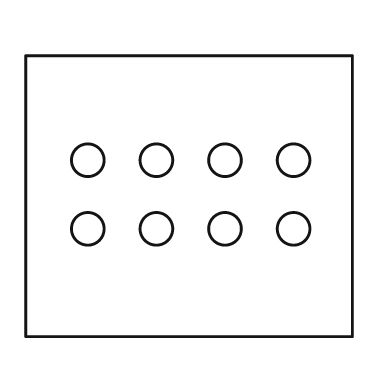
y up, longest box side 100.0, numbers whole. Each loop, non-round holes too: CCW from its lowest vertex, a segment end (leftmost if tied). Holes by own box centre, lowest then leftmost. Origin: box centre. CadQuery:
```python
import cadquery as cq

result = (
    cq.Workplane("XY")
    .moveTo(-50.0, -43.0)
    .lineTo(50.0, -43.0)
    .lineTo(50.0, 43.0)
    .lineTo(-50.0, 43.0)
    .close()
    .moveTo(-31.0, -10.0)
    .circle(5.0)
    .moveTo(-10.0, -10.0)
    .circle(5.0)
    .moveTo(11.0, -10.0)
    .circle(5.0)
    .moveTo(32.0, -10.0)
    .circle(5.0)
    .moveTo(-31.0, 11.0)
    .circle(5.0)
    .moveTo(-10.0, 11.0)
    .circle(5.0)
    .moveTo(11.0, 11.0)
    .circle(5.0)
    .moveTo(32.0, 11.0)
    .circle(5.0)
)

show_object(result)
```